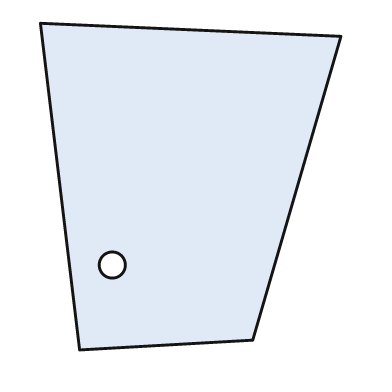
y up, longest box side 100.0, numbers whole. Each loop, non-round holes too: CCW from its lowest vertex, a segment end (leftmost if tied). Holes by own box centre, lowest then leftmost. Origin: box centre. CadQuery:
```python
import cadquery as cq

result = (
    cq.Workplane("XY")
    .moveTo(-34.0, -50.0)
    .lineTo(19.0, -47.0)
    .lineTo(46.0, 46.0)
    .lineTo(-46.0, 50.0)
    .close()
    .moveTo(-24.0, -24.0)
    .circle(4.0)
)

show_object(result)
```